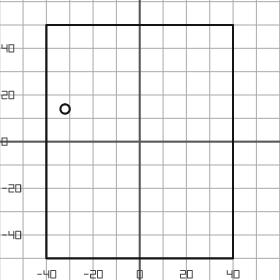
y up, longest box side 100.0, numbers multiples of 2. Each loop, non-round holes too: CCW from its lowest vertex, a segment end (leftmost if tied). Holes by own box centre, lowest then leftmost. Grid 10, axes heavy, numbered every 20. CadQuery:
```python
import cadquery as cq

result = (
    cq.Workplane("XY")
    .moveTo(-40.0, -50.0)
    .lineTo(40.0, -50.0)
    .lineTo(40.0, 50.0)
    .lineTo(-40.0, 50.0)
    .close()
    .moveTo(-32.0, 14.0)
    .circle(2.0)
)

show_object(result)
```